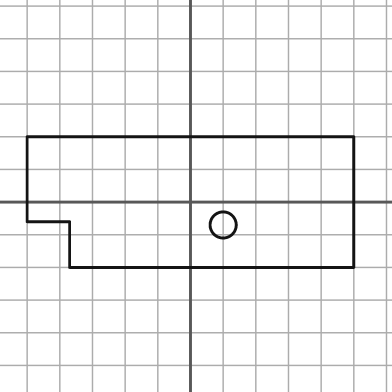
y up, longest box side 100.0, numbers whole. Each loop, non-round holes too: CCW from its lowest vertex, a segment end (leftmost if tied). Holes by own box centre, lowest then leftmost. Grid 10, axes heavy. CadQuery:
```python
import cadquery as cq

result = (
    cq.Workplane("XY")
    .moveTo(-37.0, -20.0)
    .lineTo(50.0, -20.0)
    .lineTo(50.0, 20.0)
    .lineTo(-50.0, 20.0)
    .lineTo(-50.0, -6.0)
    .lineTo(-37.0, -6.0)
    .close()
    .moveTo(10.0, -7.0)
    .circle(4.0)
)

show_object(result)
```